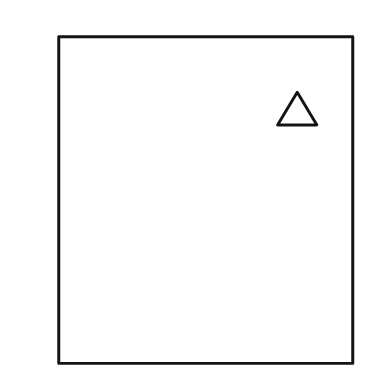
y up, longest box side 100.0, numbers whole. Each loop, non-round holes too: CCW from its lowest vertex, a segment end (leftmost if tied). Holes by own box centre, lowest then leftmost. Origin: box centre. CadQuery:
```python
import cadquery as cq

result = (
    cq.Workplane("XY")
    .moveTo(-45.0, -50.0)
    .lineTo(45.0, -50.0)
    .lineTo(45.0, 50.0)
    .lineTo(-45.0, 50.0)
    .close()
    .moveTo(22.0, 23.0)
    .lineTo(34.0, 23.0)
    .lineTo(28.0, 33.0)
    .close()
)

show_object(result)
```